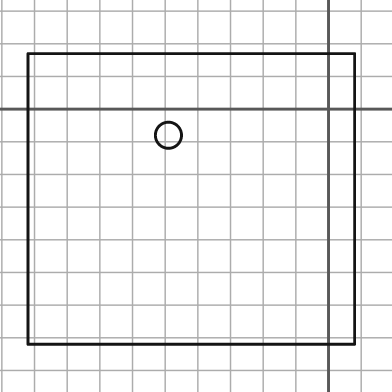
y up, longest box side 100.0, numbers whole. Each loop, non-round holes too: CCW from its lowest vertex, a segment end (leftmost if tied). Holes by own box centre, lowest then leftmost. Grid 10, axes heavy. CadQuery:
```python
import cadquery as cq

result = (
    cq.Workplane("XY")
    .moveTo(-92.0, -72.0)
    .lineTo(8.0, -72.0)
    .lineTo(8.0, 17.0)
    .lineTo(-92.0, 17.0)
    .close()
    .moveTo(-49.0, -8.0)
    .circle(4.0)
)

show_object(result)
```